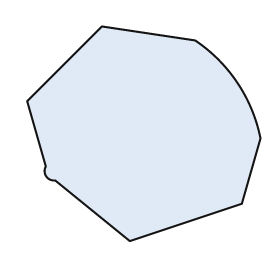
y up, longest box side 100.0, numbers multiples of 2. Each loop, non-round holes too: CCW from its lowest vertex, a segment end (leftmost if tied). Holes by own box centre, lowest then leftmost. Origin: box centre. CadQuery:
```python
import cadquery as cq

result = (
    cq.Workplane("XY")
    .moveTo(-6.0, -46.0)
    .lineTo(42.0, -30.0)
    .lineTo(50.0, -2.0)
    .threePointArc((40.0, 22.0), (22.0, 40.0))
    .lineTo(-18.0, 46.0)
    .lineTo(-50.0, 14.0)
    .lineTo(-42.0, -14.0)
    .threePointArc((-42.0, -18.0), (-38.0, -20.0))
    .close()
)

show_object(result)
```